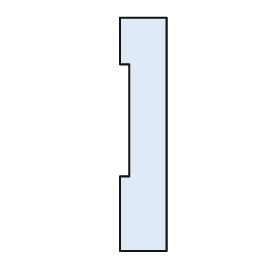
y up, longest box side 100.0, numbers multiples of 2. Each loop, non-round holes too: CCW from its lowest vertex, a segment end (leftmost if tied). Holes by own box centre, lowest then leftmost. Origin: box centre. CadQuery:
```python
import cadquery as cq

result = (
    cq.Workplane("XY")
    .moveTo(-10.0, -50.0)
    .lineTo(10.0, -50.0)
    .lineTo(10.0, 50.0)
    .lineTo(-10.0, 50.0)
    .lineTo(-10.0, 30.0)
    .lineTo(-6.0, 30.0)
    .lineTo(-6.0, -18.0)
    .lineTo(-10.0, -18.0)
    .close()
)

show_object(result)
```